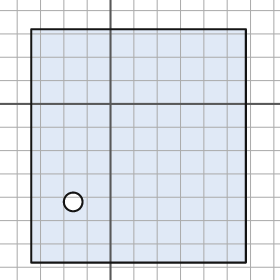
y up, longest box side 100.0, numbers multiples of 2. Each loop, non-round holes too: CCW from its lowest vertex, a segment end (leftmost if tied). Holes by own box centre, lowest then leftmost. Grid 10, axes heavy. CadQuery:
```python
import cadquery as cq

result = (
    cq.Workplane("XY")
    .moveTo(-34.0, -68.0)
    .lineTo(58.0, -68.0)
    .lineTo(58.0, 32.0)
    .lineTo(-34.0, 32.0)
    .close()
    .moveTo(-16.0, -42.0)
    .circle(4.0)
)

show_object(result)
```